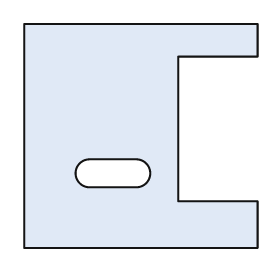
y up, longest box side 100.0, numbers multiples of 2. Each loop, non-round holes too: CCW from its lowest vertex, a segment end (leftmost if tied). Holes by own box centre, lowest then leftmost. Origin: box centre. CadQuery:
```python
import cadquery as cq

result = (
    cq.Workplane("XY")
    .moveTo(-50.0, -48.0)
    .lineTo(50.0, -48.0)
    .lineTo(50.0, -28.0)
    .lineTo(16.0, -28.0)
    .lineTo(16.0, 34.0)
    .lineTo(50.0, 34.0)
    .lineTo(50.0, 48.0)
    .lineTo(-50.0, 48.0)
    .close()
    .moveTo(-22.0, -22.0)
    .lineTo(-2.0, -22.0)
    .threePointArc((4.0, -16.0), (-2.0, -10.0))
    .lineTo(-22.0, -10.0)
    .threePointArc((-28.0, -16.0), (-22.0, -22.0))
    .close()
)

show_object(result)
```